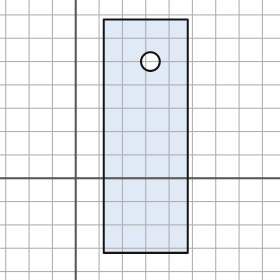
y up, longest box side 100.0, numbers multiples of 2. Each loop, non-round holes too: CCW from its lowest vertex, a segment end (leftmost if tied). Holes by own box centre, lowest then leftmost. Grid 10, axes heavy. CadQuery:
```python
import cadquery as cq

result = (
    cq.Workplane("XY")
    .moveTo(12.0, -32.0)
    .lineTo(48.0, -32.0)
    .lineTo(48.0, 68.0)
    .lineTo(12.0, 68.0)
    .close()
    .moveTo(32.0, 50.0)
    .circle(4.0)
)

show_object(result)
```